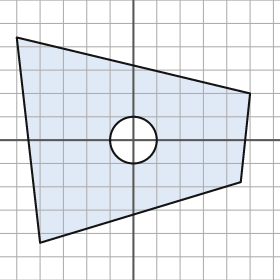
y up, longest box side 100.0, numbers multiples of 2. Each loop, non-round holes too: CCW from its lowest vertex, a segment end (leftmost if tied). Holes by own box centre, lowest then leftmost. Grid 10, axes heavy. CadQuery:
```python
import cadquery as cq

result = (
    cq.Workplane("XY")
    .moveTo(-40.0, -44.0)
    .lineTo(46.0, -18.0)
    .lineTo(50.0, 20.0)
    .lineTo(-50.0, 44.0)
    .close()
    .moveTo(0.0, 0.0)
    .circle(10.0)
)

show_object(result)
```